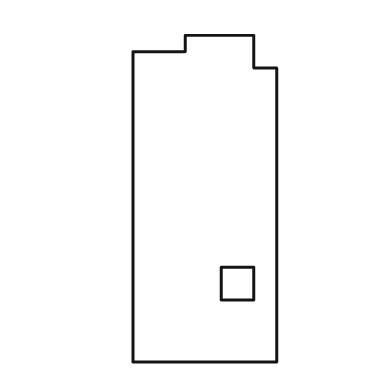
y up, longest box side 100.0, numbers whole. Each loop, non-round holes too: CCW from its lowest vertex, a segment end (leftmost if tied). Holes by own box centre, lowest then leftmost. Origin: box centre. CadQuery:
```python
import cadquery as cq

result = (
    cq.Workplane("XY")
    .moveTo(-22.0, -50.0)
    .lineTo(22.0, -50.0)
    .lineTo(22.0, 40.0)
    .lineTo(15.0, 40.0)
    .lineTo(15.0, 50.0)
    .lineTo(-6.0, 50.0)
    .lineTo(-6.0, 45.0)
    .lineTo(-22.0, 45.0)
    .close()
    .moveTo(5.0, -31.0)
    .lineTo(15.0, -31.0)
    .lineTo(15.0, -21.0)
    .lineTo(5.0, -21.0)
    .close()
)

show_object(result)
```